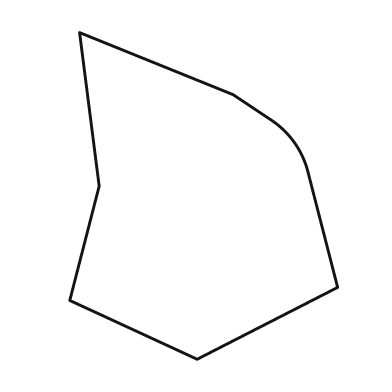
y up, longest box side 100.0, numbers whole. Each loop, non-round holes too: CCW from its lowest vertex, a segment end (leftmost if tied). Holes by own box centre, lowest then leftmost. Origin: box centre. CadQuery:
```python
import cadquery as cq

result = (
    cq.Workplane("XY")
    .moveTo(-2.0, -50.0)
    .lineTo(41.0, -28.0)
    .lineTo(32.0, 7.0)
    .threePointArc((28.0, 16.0), (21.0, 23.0))
    .lineTo(9.0, 31.0)
    .lineTo(-38.0, 50.0)
    .lineTo(-32.0, 3.0)
    .lineTo(-41.0, -32.0)
    .close()
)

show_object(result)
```